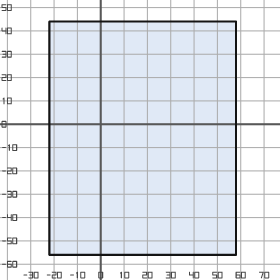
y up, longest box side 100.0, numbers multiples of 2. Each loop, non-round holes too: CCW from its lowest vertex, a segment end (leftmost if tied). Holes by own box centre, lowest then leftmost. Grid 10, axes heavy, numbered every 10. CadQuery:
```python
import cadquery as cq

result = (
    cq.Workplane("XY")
    .moveTo(-22.0, -56.0)
    .lineTo(58.0, -56.0)
    .lineTo(58.0, 44.0)
    .lineTo(-22.0, 44.0)
    .close()
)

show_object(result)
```